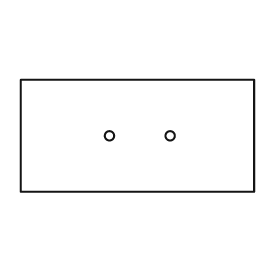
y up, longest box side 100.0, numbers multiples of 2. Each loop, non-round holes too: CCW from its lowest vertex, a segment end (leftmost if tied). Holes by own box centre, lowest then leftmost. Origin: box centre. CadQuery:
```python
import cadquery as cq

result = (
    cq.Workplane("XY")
    .moveTo(-50.0, -24.0)
    .lineTo(50.0, -24.0)
    .lineTo(50.0, 24.0)
    .lineTo(-50.0, 24.0)
    .close()
    .moveTo(-12.0, 0.0)
    .circle(2.0)
    .moveTo(14.0, 0.0)
    .circle(2.0)
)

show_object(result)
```